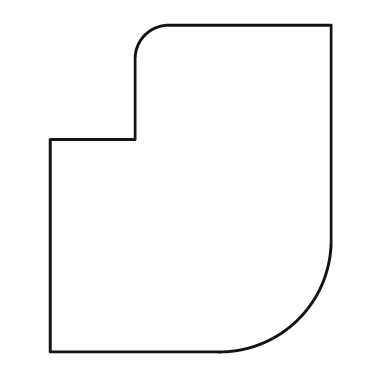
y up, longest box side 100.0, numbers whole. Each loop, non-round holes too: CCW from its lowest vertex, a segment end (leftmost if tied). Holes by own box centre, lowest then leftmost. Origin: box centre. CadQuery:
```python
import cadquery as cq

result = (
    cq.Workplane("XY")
    .moveTo(-43.0, -50.0)
    .lineTo(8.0, -50.0)
    .threePointArc((33.0, -40.0), (43.0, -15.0))
    .lineTo(43.0, 50.0)
    .lineTo(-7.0, 50.0)
    .threePointArc((-14.0, 47.0), (-17.0, 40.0))
    .lineTo(-17.0, 15.0)
    .lineTo(-43.0, 15.0)
    .close()
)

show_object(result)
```